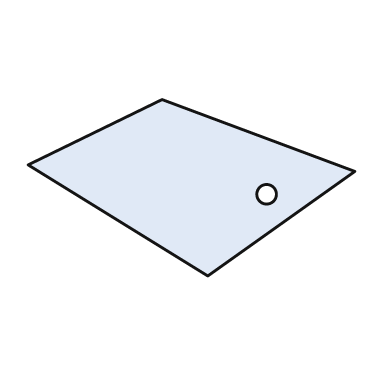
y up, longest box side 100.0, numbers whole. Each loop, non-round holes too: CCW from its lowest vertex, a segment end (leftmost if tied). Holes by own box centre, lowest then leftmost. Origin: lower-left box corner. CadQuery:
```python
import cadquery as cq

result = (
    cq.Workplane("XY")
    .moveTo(55.0, 0.0)
    .lineTo(100.0, 32.0)
    .lineTo(41.0, 54.0)
    .lineTo(0.0, 34.0)
    .close()
    .moveTo(73.0, 25.0)
    .circle(3.0)
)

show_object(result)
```